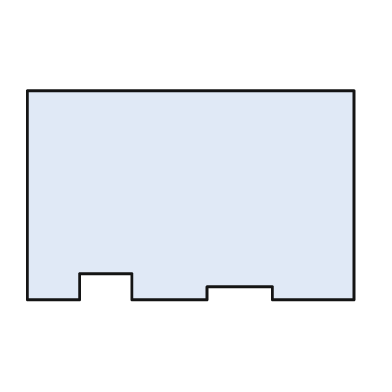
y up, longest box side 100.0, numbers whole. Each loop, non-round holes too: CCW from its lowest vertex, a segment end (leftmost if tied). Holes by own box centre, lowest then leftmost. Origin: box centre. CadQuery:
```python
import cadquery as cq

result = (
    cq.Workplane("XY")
    .moveTo(-50.0, -32.0)
    .lineTo(-34.0, -32.0)
    .lineTo(-34.0, -24.0)
    .lineTo(-18.0, -24.0)
    .lineTo(-18.0, -32.0)
    .lineTo(5.0, -32.0)
    .lineTo(5.0, -28.0)
    .lineTo(25.0, -28.0)
    .lineTo(25.0, -32.0)
    .lineTo(50.0, -32.0)
    .lineTo(50.0, 32.0)
    .lineTo(-50.0, 32.0)
    .close()
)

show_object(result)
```